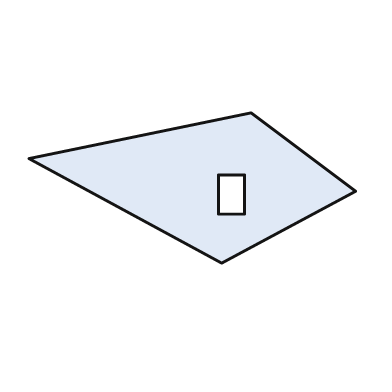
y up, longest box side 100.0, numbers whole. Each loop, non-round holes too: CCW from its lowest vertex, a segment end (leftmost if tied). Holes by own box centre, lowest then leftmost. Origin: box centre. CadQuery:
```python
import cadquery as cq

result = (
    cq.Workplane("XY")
    .moveTo(9.0, -23.0)
    .lineTo(50.0, -1.0)
    .lineTo(18.0, 23.0)
    .lineTo(-50.0, 9.0)
    .close()
    .moveTo(8.0, -8.0)
    .lineTo(16.0, -8.0)
    .lineTo(16.0, 4.0)
    .lineTo(8.0, 4.0)
    .close()
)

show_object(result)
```